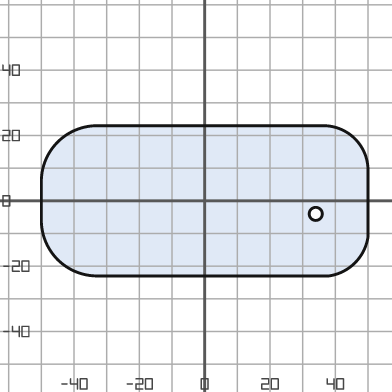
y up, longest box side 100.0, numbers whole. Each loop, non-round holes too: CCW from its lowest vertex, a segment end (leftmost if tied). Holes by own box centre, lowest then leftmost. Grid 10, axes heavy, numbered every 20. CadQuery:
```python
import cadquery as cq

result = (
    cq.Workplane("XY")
    .moveTo(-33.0, -23.0)
    .lineTo(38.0, -23.0)
    .threePointArc((46.0, -19.0), (50.0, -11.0))
    .lineTo(50.0, 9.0)
    .threePointArc((46.0, 19.0), (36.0, 23.0))
    .lineTo(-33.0, 23.0)
    .threePointArc((-45.0, 18.0), (-50.0, 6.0))
    .lineTo(-50.0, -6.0)
    .threePointArc((-45.0, -18.0), (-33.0, -23.0))
    .close()
    .moveTo(34.0, -4.0)
    .circle(2.0)
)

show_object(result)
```